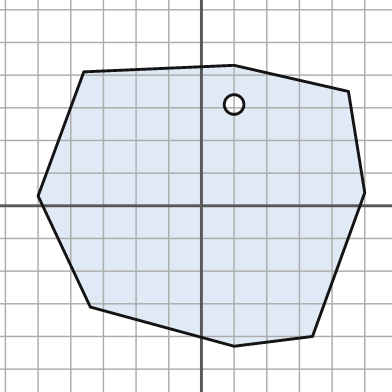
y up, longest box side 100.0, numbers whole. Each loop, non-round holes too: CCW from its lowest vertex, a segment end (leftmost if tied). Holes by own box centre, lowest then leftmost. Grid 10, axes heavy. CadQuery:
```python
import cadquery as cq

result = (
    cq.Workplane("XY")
    .moveTo(10.0, -43.0)
    .lineTo(34.0, -40.0)
    .lineTo(50.0, 4.0)
    .lineTo(45.0, 35.0)
    .lineTo(10.0, 43.0)
    .lineTo(-36.0, 41.0)
    .lineTo(-50.0, 3.0)
    .lineTo(-34.0, -31.0)
    .close()
    .moveTo(10.0, 31.0)
    .circle(3.0)
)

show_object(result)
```